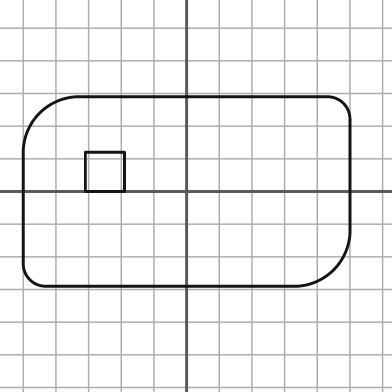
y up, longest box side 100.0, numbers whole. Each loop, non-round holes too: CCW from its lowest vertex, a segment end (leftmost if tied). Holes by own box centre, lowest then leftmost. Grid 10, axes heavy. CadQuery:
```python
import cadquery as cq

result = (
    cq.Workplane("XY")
    .moveTo(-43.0, -29.0)
    .lineTo(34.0, -29.0)
    .threePointArc((45.0, -24.0), (50.0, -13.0))
    .lineTo(50.0, 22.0)
    .threePointArc((48.0, 27.0), (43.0, 29.0))
    .lineTo(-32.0, 29.0)
    .threePointArc((-45.0, 24.0), (-50.0, 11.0))
    .lineTo(-50.0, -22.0)
    .threePointArc((-48.0, -27.0), (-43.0, -29.0))
    .close()
    .moveTo(-31.0, 0.0)
    .lineTo(-19.0, 0.0)
    .lineTo(-19.0, 12.0)
    .lineTo(-31.0, 12.0)
    .close()
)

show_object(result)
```